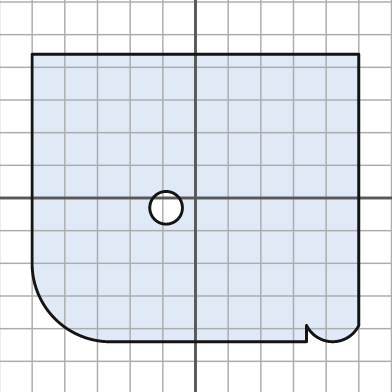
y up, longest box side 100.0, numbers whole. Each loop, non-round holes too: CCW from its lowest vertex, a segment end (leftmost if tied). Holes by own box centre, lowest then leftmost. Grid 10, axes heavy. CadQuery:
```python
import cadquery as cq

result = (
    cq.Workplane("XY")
    .moveTo(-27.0, -44.0)
    .lineTo(34.0, -44.0)
    .lineTo(34.0, -39.0)
    .threePointArc((42.0, -44.0), (50.0, -39.0))
    .lineTo(50.0, 44.0)
    .lineTo(-50.0, 44.0)
    .lineTo(-50.0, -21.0)
    .threePointArc((-43.0, -37.0), (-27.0, -44.0))
    .close()
    .moveTo(-9.0, -3.0)
    .circle(5.0)
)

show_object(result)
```